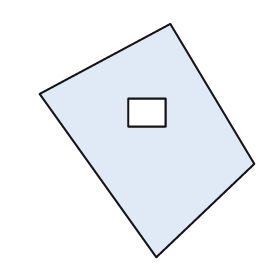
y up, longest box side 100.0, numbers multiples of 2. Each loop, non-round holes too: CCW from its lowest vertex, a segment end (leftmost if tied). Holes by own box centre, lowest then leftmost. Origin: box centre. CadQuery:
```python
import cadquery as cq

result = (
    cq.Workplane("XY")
    .moveTo(4.0, -50.0)
    .lineTo(46.0, -10.0)
    .lineTo(10.0, 50.0)
    .lineTo(-46.0, 20.0)
    .close()
    .moveTo(-8.0, 6.0)
    .lineTo(8.0, 6.0)
    .lineTo(8.0, 18.0)
    .lineTo(-8.0, 18.0)
    .close()
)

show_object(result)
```